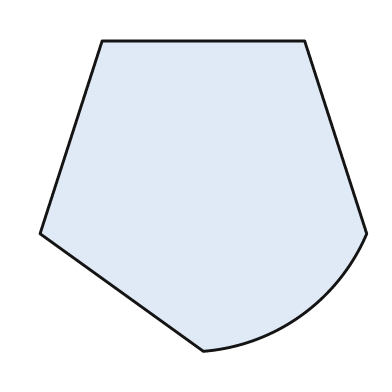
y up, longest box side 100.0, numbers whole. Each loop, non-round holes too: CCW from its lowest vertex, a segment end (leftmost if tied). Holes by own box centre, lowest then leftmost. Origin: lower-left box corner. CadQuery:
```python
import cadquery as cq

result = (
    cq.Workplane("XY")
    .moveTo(50.0, 0.0)
    .threePointArc((80.0, 11.0), (100.0, 36.0))
    .lineTo(81.0, 95.0)
    .lineTo(19.0, 95.0)
    .lineTo(0.0, 36.0)
    .close()
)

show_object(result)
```